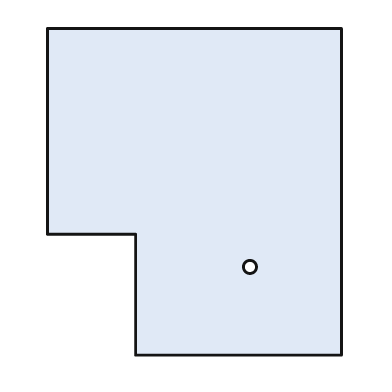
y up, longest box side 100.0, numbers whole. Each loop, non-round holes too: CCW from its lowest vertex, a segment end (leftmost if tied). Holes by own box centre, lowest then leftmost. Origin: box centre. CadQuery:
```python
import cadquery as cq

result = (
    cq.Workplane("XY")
    .moveTo(-18.0, -50.0)
    .lineTo(45.0, -50.0)
    .lineTo(45.0, 50.0)
    .lineTo(-45.0, 50.0)
    .lineTo(-45.0, -13.0)
    .lineTo(-18.0, -13.0)
    .close()
    .moveTo(17.0, -23.0)
    .circle(2.0)
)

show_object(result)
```